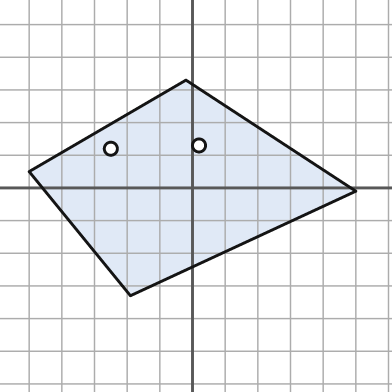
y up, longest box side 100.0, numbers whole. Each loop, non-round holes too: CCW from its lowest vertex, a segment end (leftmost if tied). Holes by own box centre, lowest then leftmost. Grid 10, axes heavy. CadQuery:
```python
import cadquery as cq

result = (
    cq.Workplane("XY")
    .moveTo(-19.0, -33.0)
    .lineTo(50.0, -1.0)
    .lineTo(-2.0, 33.0)
    .lineTo(-50.0, 5.0)
    .close()
    .moveTo(-25.0, 12.0)
    .circle(2.0)
    .moveTo(2.0, 13.0)
    .circle(2.0)
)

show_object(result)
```